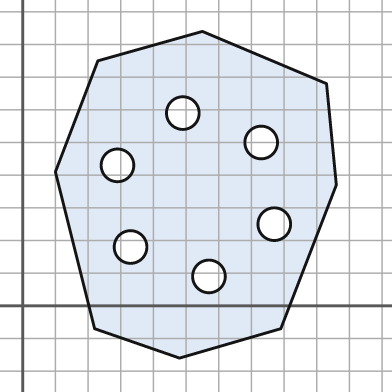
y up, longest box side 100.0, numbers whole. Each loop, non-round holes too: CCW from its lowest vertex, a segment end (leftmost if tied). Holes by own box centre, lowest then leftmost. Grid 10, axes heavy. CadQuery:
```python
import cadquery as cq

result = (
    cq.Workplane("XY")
    .moveTo(48.0, -16.0)
    .lineTo(79.0, -7.0)
    .lineTo(96.0, 37.0)
    .lineTo(93.0, 68.0)
    .lineTo(55.0, 84.0)
    .lineTo(23.0, 75.0)
    .lineTo(10.0, 41.0)
    .lineTo(22.0, -7.0)
    .close()
    .moveTo(57.0, 9.0)
    .circle(5.0)
    .moveTo(33.0, 18.0)
    .circle(5.0)
    .moveTo(77.0, 25.0)
    .circle(5.0)
    .moveTo(29.0, 43.0)
    .circle(5.0)
    .moveTo(73.0, 50.0)
    .circle(5.0)
    .moveTo(49.0, 59.0)
    .circle(5.0)
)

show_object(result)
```